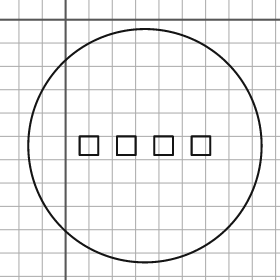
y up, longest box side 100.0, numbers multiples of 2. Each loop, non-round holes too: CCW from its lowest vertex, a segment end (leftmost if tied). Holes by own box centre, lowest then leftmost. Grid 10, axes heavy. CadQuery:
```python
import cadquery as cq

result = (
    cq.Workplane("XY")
    .moveTo(34.0, -54.0)
    .circle(50.0)
    .moveTo(6.0, -58.0)
    .lineTo(14.0, -58.0)
    .lineTo(14.0, -50.0)
    .lineTo(6.0, -50.0)
    .close()
    .moveTo(22.0, -58.0)
    .lineTo(30.0, -58.0)
    .lineTo(30.0, -50.0)
    .lineTo(22.0, -50.0)
    .close()
    .moveTo(38.0, -58.0)
    .lineTo(46.0, -58.0)
    .lineTo(46.0, -50.0)
    .lineTo(38.0, -50.0)
    .close()
    .moveTo(54.0, -58.0)
    .lineTo(62.0, -58.0)
    .lineTo(62.0, -50.0)
    .lineTo(54.0, -50.0)
    .close()
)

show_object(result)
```